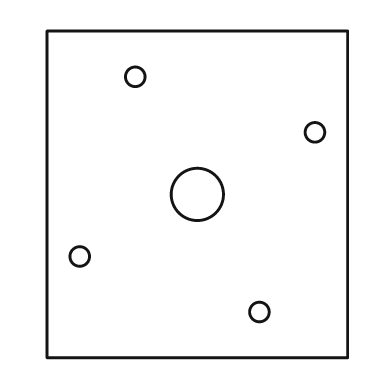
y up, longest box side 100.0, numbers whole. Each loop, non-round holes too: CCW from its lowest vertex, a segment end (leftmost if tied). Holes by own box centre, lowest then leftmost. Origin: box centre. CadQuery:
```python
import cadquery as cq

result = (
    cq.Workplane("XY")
    .moveTo(-46.0, -50.0)
    .lineTo(46.0, -50.0)
    .lineTo(46.0, 50.0)
    .lineTo(-46.0, 50.0)
    .close()
    .moveTo(19.0, -36.0)
    .circle(3.0)
    .moveTo(-36.0, -19.0)
    .circle(3.0)
    .moveTo(0.0, 0.0)
    .circle(8.0)
    .moveTo(36.0, 19.0)
    .circle(3.0)
    .moveTo(-19.0, 36.0)
    .circle(3.0)
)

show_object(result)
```